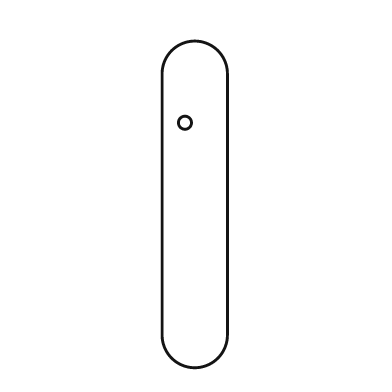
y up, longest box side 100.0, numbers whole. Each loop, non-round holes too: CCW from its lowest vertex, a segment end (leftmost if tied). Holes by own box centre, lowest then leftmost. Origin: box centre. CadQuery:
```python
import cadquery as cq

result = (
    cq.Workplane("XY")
    .moveTo(-10.0, -40.0)
    .threePointArc((0.0, -50.0), (10.0, -40.0))
    .lineTo(10.0, 40.0)
    .threePointArc((0.0, 50.0), (-10.0, 40.0))
    .close()
    .moveTo(-3.0, 25.0)
    .circle(2.0)
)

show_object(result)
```